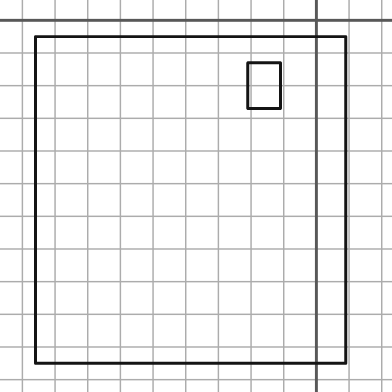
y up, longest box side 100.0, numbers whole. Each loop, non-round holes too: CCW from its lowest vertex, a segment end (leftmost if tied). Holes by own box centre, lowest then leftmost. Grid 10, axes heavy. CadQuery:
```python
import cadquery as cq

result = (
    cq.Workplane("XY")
    .moveTo(-86.0, -105.0)
    .lineTo(9.0, -105.0)
    .lineTo(9.0, -5.0)
    .lineTo(-86.0, -5.0)
    .close()
    .moveTo(-21.0, -27.0)
    .lineTo(-11.0, -27.0)
    .lineTo(-11.0, -13.0)
    .lineTo(-21.0, -13.0)
    .close()
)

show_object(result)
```